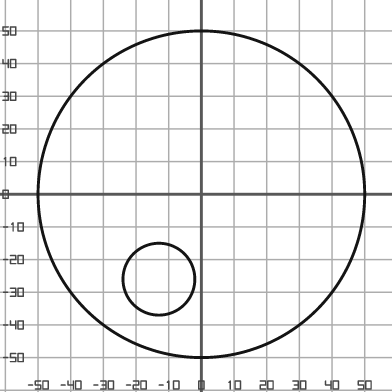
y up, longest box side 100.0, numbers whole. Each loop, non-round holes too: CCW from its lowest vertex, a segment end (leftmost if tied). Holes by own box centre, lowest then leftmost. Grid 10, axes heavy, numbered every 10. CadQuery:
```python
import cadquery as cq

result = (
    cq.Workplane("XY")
    .moveTo(0.0, 0.0)
    .circle(50.0)
    .moveTo(-13.0, -26.0)
    .circle(11.0)
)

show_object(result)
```